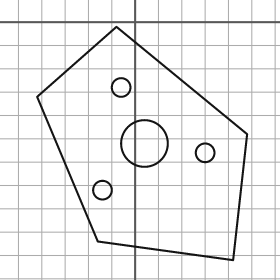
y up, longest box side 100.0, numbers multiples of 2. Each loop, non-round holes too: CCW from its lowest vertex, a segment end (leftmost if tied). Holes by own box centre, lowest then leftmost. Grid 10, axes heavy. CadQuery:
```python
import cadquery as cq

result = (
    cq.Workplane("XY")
    .moveTo(42.0, -102.0)
    .lineTo(48.0, -48.0)
    .lineTo(-8.0, -2.0)
    .lineTo(-42.0, -32.0)
    .lineTo(-16.0, -94.0)
    .close()
    .moveTo(-14.0, -72.0)
    .circle(4.0)
    .moveTo(30.0, -56.0)
    .circle(4.0)
    .moveTo(4.0, -52.0)
    .circle(10.0)
    .moveTo(-6.0, -28.0)
    .circle(4.0)
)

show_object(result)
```